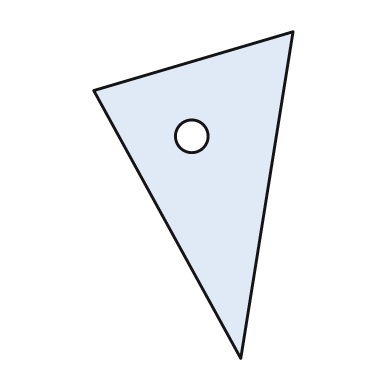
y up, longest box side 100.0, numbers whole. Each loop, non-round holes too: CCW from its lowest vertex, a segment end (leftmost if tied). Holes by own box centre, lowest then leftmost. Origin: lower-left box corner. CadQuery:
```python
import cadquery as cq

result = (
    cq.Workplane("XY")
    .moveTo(45.0, 0.0)
    .lineTo(61.0, 100.0)
    .lineTo(0.0, 82.0)
    .close()
    .moveTo(30.0, 68.0)
    .circle(5.0)
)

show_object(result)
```